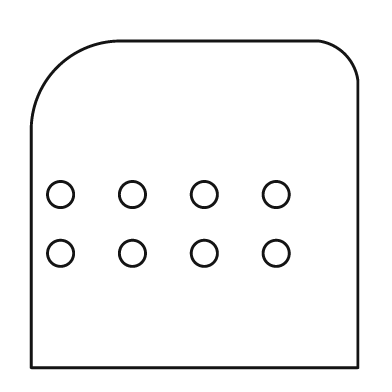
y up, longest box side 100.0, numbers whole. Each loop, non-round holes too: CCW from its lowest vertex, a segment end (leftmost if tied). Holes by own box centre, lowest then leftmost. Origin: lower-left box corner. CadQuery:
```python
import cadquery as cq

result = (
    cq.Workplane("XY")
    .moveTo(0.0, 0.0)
    .lineTo(100.0, 0.0)
    .lineTo(100.0, 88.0)
    .threePointArc((96.0, 96.0), (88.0, 100.0))
    .lineTo(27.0, 100.0)
    .threePointArc((8.0, 92.0), (0.0, 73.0))
    .close()
    .moveTo(9.0, 35.0)
    .circle(4.0)
    .moveTo(31.0, 35.0)
    .circle(4.0)
    .moveTo(53.0, 35.0)
    .circle(4.0)
    .moveTo(75.0, 35.0)
    .circle(4.0)
    .moveTo(9.0, 53.0)
    .circle(4.0)
    .moveTo(31.0, 53.0)
    .circle(4.0)
    .moveTo(53.0, 53.0)
    .circle(4.0)
    .moveTo(75.0, 53.0)
    .circle(4.0)
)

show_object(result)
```